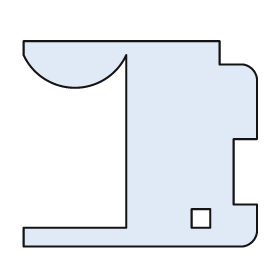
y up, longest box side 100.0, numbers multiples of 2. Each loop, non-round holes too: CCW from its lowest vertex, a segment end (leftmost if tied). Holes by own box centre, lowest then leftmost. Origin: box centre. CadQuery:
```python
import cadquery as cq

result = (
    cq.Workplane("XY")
    .moveTo(-50.0, -44.0)
    .lineTo(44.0, -44.0)
    .threePointArc((48.0, -42.0), (50.0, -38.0))
    .lineTo(50.0, -26.0)
    .lineTo(40.0, -26.0)
    .lineTo(40.0, 2.0)
    .lineTo(50.0, 2.0)
    .lineTo(50.0, 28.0)
    .threePointArc((48.0, 32.0), (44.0, 34.0))
    .lineTo(34.0, 34.0)
    .lineTo(34.0, 44.0)
    .lineTo(-50.0, 44.0)
    .lineTo(-50.0, 38.0)
    .threePointArc((-28.0, 24.0), (-6.0, 38.0))
    .lineTo(-6.0, -36.0)
    .lineTo(-50.0, -36.0)
    .close()
    .moveTo(22.0, -36.0)
    .lineTo(30.0, -36.0)
    .lineTo(30.0, -28.0)
    .lineTo(22.0, -28.0)
    .close()
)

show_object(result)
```